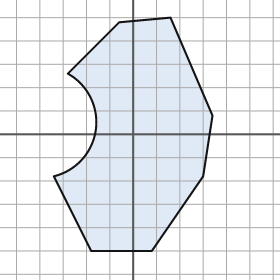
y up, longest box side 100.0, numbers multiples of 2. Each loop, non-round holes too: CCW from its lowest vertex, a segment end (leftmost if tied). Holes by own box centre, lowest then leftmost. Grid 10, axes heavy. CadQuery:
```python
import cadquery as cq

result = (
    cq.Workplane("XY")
    .moveTo(-18.0, -50.0)
    .lineTo(8.0, -50.0)
    .lineTo(30.0, -18.0)
    .lineTo(34.0, 8.0)
    .lineTo(16.0, 50.0)
    .lineTo(-6.0, 48.0)
    .lineTo(-28.0, 26.0)
    .threePointArc((-16.0, 2.0), (-34.0, -18.0))
    .close()
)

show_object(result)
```